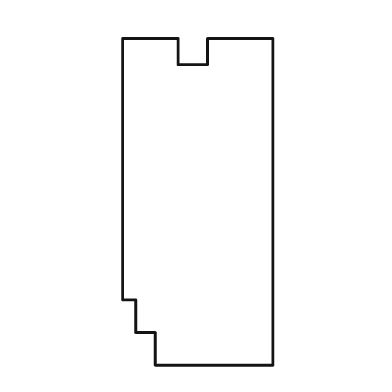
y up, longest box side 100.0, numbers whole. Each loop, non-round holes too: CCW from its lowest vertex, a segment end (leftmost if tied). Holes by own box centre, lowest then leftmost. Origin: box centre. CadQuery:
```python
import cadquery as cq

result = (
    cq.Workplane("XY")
    .moveTo(-13.0, -50.0)
    .lineTo(23.0, -50.0)
    .lineTo(23.0, 50.0)
    .lineTo(3.0, 50.0)
    .lineTo(3.0, 42.0)
    .lineTo(-6.0, 42.0)
    .lineTo(-6.0, 50.0)
    .lineTo(-23.0, 50.0)
    .lineTo(-23.0, -30.0)
    .lineTo(-19.0, -30.0)
    .lineTo(-19.0, -40.0)
    .lineTo(-13.0, -40.0)
    .close()
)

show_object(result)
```